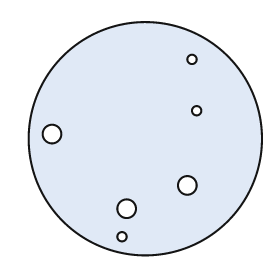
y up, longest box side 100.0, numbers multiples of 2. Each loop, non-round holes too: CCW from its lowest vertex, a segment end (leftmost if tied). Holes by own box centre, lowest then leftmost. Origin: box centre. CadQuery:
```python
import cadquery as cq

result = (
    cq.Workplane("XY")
    .moveTo(0.0, 0.0)
    .circle(50.0)
    .moveTo(-10.0, -42.0)
    .circle(2.0)
    .moveTo(-8.0, -30.0)
    .circle(4.0)
    .moveTo(18.0, -20.0)
    .circle(4.0)
    .moveTo(-40.0, 2.0)
    .circle(4.0)
    .moveTo(22.0, 12.0)
    .circle(2.0)
    .moveTo(20.0, 34.0)
    .circle(2.0)
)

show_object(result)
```